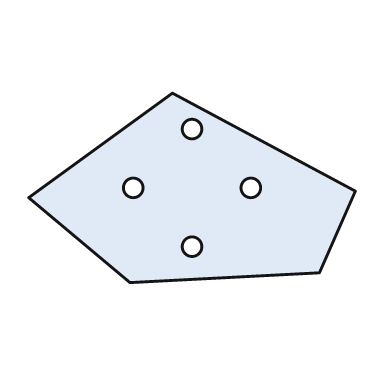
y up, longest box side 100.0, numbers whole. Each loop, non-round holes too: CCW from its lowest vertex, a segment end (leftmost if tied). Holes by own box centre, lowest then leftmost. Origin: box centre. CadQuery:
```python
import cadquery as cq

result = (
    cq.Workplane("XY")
    .moveTo(-19.0, -29.0)
    .lineTo(39.0, -26.0)
    .lineTo(50.0, -1.0)
    .lineTo(-6.0, 29.0)
    .lineTo(-50.0, -3.0)
    .close()
    .moveTo(0.0, -18.0)
    .circle(3.0)
    .moveTo(-18.0, 0.0)
    .circle(3.0)
    .moveTo(18.0, 0.0)
    .circle(3.0)
    .moveTo(0.0, 18.0)
    .circle(3.0)
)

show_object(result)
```